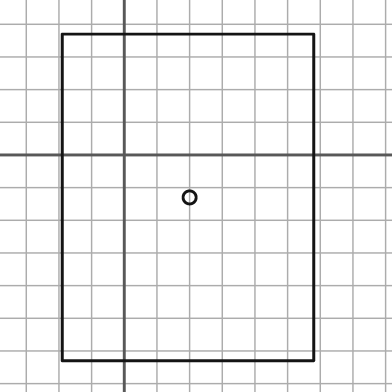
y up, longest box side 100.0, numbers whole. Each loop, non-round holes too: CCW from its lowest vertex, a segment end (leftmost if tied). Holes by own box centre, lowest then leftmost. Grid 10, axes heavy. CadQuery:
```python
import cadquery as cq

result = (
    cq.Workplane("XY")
    .moveTo(-19.0, -63.0)
    .lineTo(58.0, -63.0)
    .lineTo(58.0, 37.0)
    .lineTo(-19.0, 37.0)
    .close()
    .moveTo(20.0, -13.0)
    .circle(2.0)
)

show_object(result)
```